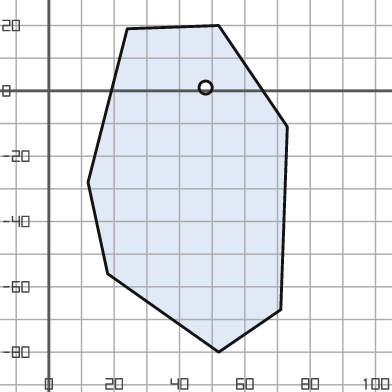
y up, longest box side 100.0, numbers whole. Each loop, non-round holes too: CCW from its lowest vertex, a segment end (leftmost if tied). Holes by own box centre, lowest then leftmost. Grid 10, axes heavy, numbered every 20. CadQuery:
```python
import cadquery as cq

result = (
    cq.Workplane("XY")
    .moveTo(52.0, -80.0)
    .lineTo(71.0, -67.0)
    .lineTo(73.0, -11.0)
    .lineTo(52.0, 20.0)
    .lineTo(24.0, 19.0)
    .lineTo(12.0, -28.0)
    .lineTo(18.0, -56.0)
    .close()
    .moveTo(48.0, 1.0)
    .circle(2.0)
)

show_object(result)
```